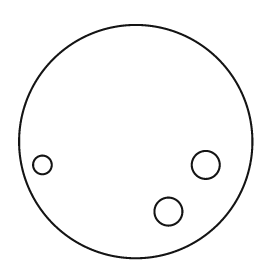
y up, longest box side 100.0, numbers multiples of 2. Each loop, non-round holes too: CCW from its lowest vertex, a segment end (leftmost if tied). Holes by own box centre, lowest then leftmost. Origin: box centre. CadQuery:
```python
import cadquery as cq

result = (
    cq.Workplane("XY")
    .moveTo(0.0, 0.0)
    .circle(50.0)
    .moveTo(14.0, -30.0)
    .circle(6.0)
    .moveTo(-40.0, -10.0)
    .circle(4.0)
    .moveTo(30.0, -10.0)
    .circle(6.0)
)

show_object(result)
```